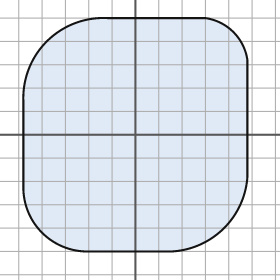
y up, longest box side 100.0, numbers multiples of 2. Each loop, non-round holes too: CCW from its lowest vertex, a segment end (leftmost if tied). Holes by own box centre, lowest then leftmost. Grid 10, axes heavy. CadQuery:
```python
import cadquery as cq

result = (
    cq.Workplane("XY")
    .moveTo(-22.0, -50.0)
    .lineTo(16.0, -50.0)
    .threePointArc((38.0, -40.0), (48.0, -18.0))
    .lineTo(48.0, 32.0)
    .threePointArc((42.0, 44.0), (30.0, 50.0))
    .lineTo(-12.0, 50.0)
    .threePointArc((-38.0, 40.0), (-48.0, 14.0))
    .lineTo(-48.0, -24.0)
    .threePointArc((-40.0, -42.0), (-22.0, -50.0))
    .close()
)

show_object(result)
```